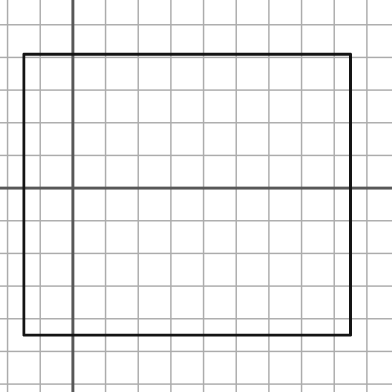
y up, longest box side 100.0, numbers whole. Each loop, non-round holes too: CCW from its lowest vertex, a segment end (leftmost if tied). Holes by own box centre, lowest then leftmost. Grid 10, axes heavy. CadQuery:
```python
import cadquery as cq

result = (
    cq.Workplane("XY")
    .moveTo(-15.0, -45.0)
    .lineTo(85.0, -45.0)
    .lineTo(85.0, 41.0)
    .lineTo(-15.0, 41.0)
    .close()
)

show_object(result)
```